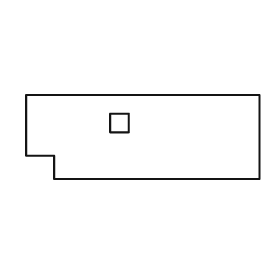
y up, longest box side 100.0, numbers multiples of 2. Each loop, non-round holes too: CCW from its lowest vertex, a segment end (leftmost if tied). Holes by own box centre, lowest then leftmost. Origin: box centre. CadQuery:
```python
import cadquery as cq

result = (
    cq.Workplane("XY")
    .moveTo(-38.0, -18.0)
    .lineTo(50.0, -18.0)
    .lineTo(50.0, 18.0)
    .lineTo(-50.0, 18.0)
    .lineTo(-50.0, -8.0)
    .lineTo(-38.0, -8.0)
    .close()
    .moveTo(-14.0, 2.0)
    .lineTo(-6.0, 2.0)
    .lineTo(-6.0, 10.0)
    .lineTo(-14.0, 10.0)
    .close()
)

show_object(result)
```